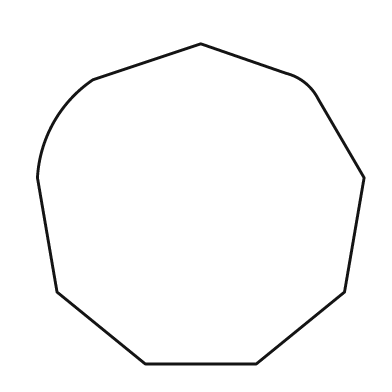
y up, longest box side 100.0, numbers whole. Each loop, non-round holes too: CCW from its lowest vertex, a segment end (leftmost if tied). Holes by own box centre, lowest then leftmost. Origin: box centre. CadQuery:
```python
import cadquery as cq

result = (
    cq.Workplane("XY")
    .moveTo(-17.0, -49.0)
    .lineTo(17.0, -49.0)
    .lineTo(44.0, -27.0)
    .lineTo(50.0, 8.0)
    .lineTo(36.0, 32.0)
    .threePointArc((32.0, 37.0), (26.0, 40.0))
    .lineTo(0.0, 49.0)
    .lineTo(-33.0, 38.0)
    .threePointArc((-45.0, 25.0), (-50.0, 8.0))
    .lineTo(-44.0, -27.0)
    .close()
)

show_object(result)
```